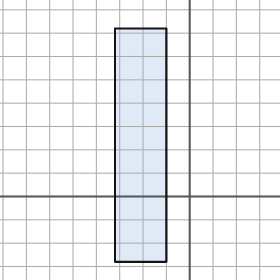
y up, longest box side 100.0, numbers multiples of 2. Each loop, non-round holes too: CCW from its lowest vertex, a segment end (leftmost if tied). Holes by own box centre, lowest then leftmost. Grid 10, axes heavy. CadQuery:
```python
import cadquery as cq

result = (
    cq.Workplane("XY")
    .moveTo(-32.0, -28.0)
    .lineTo(-10.0, -28.0)
    .lineTo(-10.0, 72.0)
    .lineTo(-32.0, 72.0)
    .close()
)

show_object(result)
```